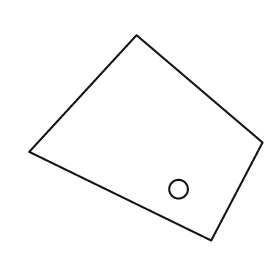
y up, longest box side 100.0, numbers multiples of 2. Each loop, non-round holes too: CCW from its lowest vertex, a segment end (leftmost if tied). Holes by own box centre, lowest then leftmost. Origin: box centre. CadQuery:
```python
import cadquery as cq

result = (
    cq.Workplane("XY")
    .moveTo(28.0, -44.0)
    .lineTo(50.0, -2.0)
    .lineTo(-4.0, 44.0)
    .lineTo(-50.0, -6.0)
    .close()
    .moveTo(14.0, -22.0)
    .circle(4.0)
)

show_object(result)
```